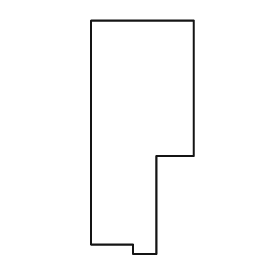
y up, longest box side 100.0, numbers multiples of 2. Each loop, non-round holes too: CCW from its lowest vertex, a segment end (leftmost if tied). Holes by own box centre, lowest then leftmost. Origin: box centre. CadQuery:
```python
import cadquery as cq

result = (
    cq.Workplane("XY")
    .moveTo(-4.0, -50.0)
    .lineTo(6.0, -50.0)
    .lineTo(6.0, -8.0)
    .lineTo(22.0, -8.0)
    .lineTo(22.0, 50.0)
    .lineTo(-22.0, 50.0)
    .lineTo(-22.0, -46.0)
    .lineTo(-4.0, -46.0)
    .close()
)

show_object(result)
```